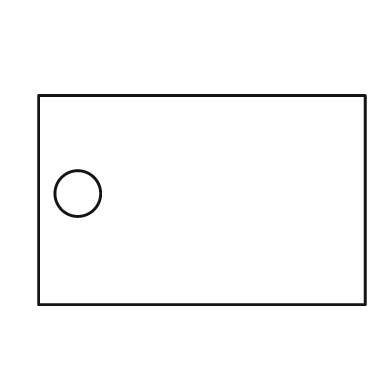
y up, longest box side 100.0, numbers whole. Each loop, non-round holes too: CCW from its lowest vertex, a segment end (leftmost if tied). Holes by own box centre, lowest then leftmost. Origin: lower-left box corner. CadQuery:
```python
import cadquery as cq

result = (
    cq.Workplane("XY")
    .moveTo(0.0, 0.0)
    .lineTo(100.0, 0.0)
    .lineTo(100.0, 64.0)
    .lineTo(0.0, 64.0)
    .close()
    .moveTo(12.0, 34.0)
    .circle(7.0)
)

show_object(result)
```